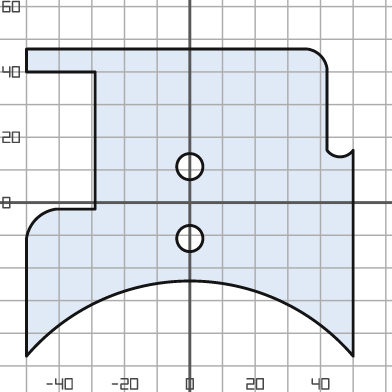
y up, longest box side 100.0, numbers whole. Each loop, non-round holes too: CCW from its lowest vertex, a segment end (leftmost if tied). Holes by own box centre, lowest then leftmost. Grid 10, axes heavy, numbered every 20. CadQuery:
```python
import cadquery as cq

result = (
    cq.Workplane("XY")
    .moveTo(-50.0, -47.0)
    .threePointArc((0.0, -24.0), (50.0, -47.0))
    .lineTo(50.0, 16.0)
    .threePointArc((46.0, 14.0), (42.0, 16.0))
    .lineTo(42.0, 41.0)
    .threePointArc((40.0, 45.0), (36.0, 47.0))
    .lineTo(-50.0, 47.0)
    .lineTo(-50.0, 40.0)
    .lineTo(-29.0, 40.0)
    .lineTo(-29.0, -2.0)
    .lineTo(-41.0, -2.0)
    .threePointArc((-47.0, -5.0), (-50.0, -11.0))
    .close()
    .moveTo(0.0, -11.0)
    .circle(4.0)
    .moveTo(0.0, 11.0)
    .circle(4.0)
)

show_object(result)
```